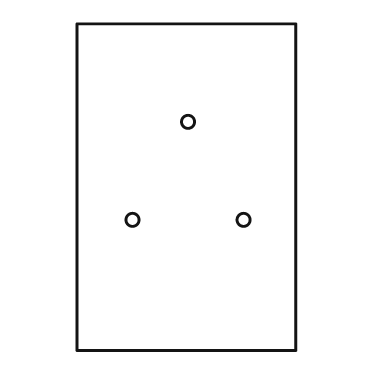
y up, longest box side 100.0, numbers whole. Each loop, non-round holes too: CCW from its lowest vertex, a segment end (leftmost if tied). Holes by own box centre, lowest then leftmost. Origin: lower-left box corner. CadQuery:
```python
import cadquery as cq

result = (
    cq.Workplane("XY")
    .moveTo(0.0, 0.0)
    .lineTo(67.0, 0.0)
    .lineTo(67.0, 100.0)
    .lineTo(0.0, 100.0)
    .close()
    .moveTo(17.0, 40.0)
    .circle(2.0)
    .moveTo(51.0, 40.0)
    .circle(2.0)
    .moveTo(34.0, 70.0)
    .circle(2.0)
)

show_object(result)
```